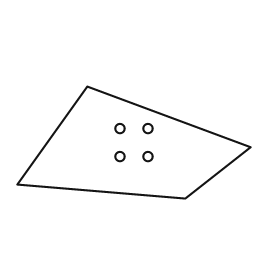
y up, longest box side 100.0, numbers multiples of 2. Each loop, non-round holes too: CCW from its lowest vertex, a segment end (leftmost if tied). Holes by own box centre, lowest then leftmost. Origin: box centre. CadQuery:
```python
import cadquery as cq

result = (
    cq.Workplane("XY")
    .moveTo(22.0, -24.0)
    .lineTo(50.0, -2.0)
    .lineTo(-20.0, 24.0)
    .lineTo(-50.0, -18.0)
    .close()
    .moveTo(-6.0, -6.0)
    .circle(2.0)
    .moveTo(6.0, -6.0)
    .circle(2.0)
    .moveTo(-6.0, 6.0)
    .circle(2.0)
    .moveTo(6.0, 6.0)
    .circle(2.0)
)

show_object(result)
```